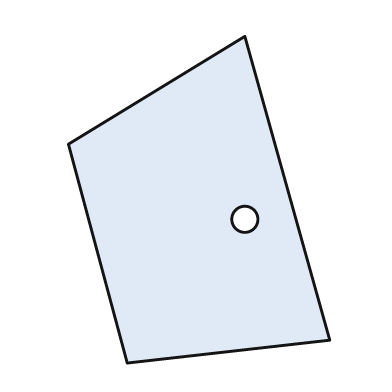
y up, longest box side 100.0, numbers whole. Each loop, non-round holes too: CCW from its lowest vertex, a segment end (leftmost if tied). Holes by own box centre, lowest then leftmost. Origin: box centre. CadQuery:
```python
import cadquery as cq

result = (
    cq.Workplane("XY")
    .moveTo(-22.0, -50.0)
    .lineTo(40.0, -43.0)
    .lineTo(14.0, 50.0)
    .lineTo(-40.0, 17.0)
    .close()
    .moveTo(14.0, -6.0)
    .circle(4.0)
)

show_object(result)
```